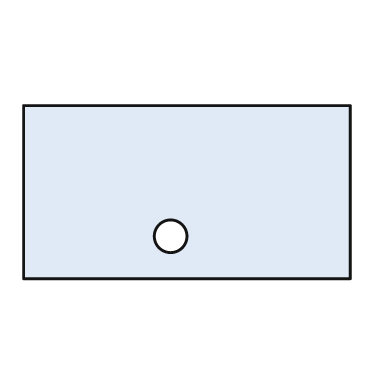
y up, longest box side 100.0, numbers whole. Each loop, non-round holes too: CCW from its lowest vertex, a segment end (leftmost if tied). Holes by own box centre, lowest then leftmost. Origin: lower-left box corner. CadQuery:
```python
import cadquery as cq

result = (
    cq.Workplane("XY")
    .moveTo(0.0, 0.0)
    .lineTo(100.0, 0.0)
    .lineTo(100.0, 53.0)
    .lineTo(0.0, 53.0)
    .close()
    .moveTo(45.0, 13.0)
    .circle(5.0)
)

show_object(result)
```